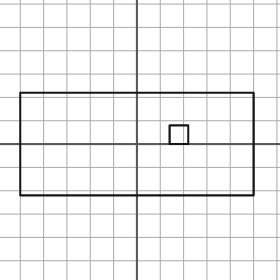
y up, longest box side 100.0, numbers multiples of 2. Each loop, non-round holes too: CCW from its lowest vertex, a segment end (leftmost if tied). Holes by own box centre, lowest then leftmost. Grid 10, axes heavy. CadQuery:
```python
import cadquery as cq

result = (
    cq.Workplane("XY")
    .moveTo(-50.0, -22.0)
    .lineTo(50.0, -22.0)
    .lineTo(50.0, 22.0)
    .lineTo(-50.0, 22.0)
    .close()
    .moveTo(14.0, 0.0)
    .lineTo(22.0, 0.0)
    .lineTo(22.0, 8.0)
    .lineTo(14.0, 8.0)
    .close()
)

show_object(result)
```